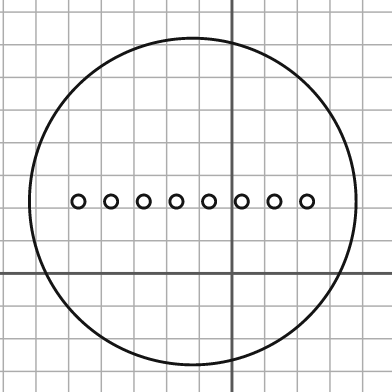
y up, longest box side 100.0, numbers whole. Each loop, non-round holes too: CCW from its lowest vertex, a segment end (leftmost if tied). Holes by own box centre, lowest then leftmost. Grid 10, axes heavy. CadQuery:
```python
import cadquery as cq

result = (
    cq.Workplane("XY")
    .moveTo(-12.0, 22.0)
    .circle(50.0)
    .moveTo(-47.0, 22.0)
    .circle(2.0)
    .moveTo(-37.0, 22.0)
    .circle(2.0)
    .moveTo(-27.0, 22.0)
    .circle(2.0)
    .moveTo(-17.0, 22.0)
    .circle(2.0)
    .moveTo(-7.0, 22.0)
    .circle(2.0)
    .moveTo(3.0, 22.0)
    .circle(2.0)
    .moveTo(13.0, 22.0)
    .circle(2.0)
    .moveTo(23.0, 22.0)
    .circle(2.0)
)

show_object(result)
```